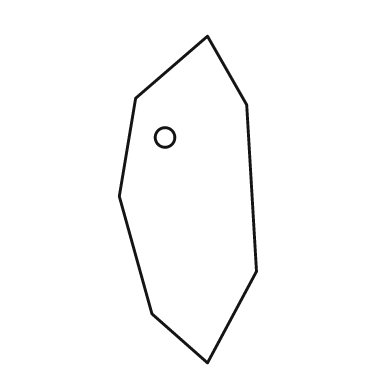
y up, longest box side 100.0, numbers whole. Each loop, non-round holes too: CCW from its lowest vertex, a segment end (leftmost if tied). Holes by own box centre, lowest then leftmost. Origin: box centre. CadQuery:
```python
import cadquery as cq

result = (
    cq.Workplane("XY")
    .moveTo(6.0, -50.0)
    .lineTo(21.0, -22.0)
    .lineTo(18.0, 29.0)
    .lineTo(6.0, 50.0)
    .lineTo(-16.0, 31.0)
    .lineTo(-21.0, 1.0)
    .lineTo(-11.0, -35.0)
    .close()
    .moveTo(-7.0, 19.0)
    .circle(3.0)
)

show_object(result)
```